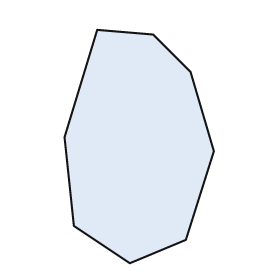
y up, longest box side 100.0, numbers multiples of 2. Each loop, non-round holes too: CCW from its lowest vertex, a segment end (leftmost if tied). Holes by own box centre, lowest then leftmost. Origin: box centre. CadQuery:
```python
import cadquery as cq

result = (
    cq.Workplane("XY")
    .moveTo(-4.0, -50.0)
    .lineTo(20.0, -40.0)
    .lineTo(32.0, -2.0)
    .lineTo(22.0, 32.0)
    .lineTo(6.0, 48.0)
    .lineTo(-18.0, 50.0)
    .lineTo(-32.0, 4.0)
    .lineTo(-28.0, -34.0)
    .close()
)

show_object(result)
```